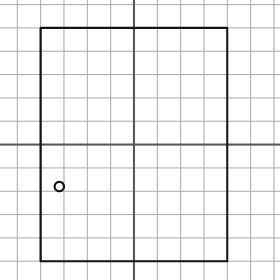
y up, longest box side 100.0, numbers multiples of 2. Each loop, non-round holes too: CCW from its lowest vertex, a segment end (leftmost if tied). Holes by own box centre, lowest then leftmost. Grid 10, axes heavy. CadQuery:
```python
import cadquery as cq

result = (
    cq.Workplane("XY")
    .moveTo(-40.0, -50.0)
    .lineTo(40.0, -50.0)
    .lineTo(40.0, 50.0)
    .lineTo(-40.0, 50.0)
    .close()
    .moveTo(-32.0, -18.0)
    .circle(2.0)
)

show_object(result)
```